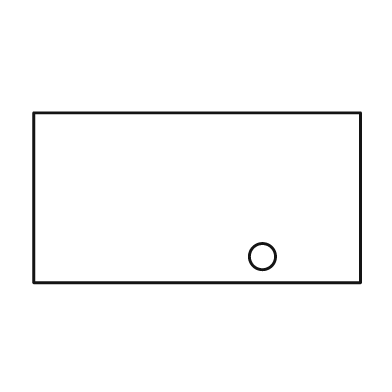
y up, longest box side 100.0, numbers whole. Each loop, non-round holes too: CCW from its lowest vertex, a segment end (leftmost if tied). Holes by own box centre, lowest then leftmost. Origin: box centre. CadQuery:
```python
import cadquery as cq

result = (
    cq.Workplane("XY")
    .moveTo(-50.0, -26.0)
    .lineTo(50.0, -26.0)
    .lineTo(50.0, 26.0)
    .lineTo(-50.0, 26.0)
    .close()
    .moveTo(20.0, -18.0)
    .circle(4.0)
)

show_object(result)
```